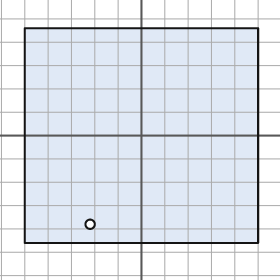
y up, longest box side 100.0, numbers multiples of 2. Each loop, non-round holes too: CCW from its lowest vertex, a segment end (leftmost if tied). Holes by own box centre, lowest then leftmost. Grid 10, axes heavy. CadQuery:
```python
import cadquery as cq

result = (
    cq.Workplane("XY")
    .moveTo(-50.0, -46.0)
    .lineTo(50.0, -46.0)
    .lineTo(50.0, 46.0)
    .lineTo(-50.0, 46.0)
    .close()
    .moveTo(-22.0, -38.0)
    .circle(2.0)
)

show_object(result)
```